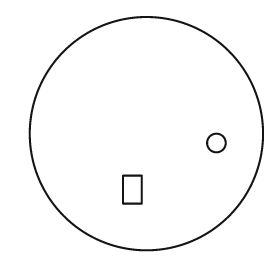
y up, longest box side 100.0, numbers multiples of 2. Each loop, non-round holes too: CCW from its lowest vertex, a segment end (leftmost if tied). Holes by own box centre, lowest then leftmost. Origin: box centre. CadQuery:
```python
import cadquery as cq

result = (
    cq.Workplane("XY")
    .moveTo(0.0, 0.0)
    .circle(50.0)
    .moveTo(-10.0, -30.0)
    .lineTo(-2.0, -30.0)
    .lineTo(-2.0, -18.0)
    .lineTo(-10.0, -18.0)
    .close()
    .moveTo(30.0, -4.0)
    .circle(4.0)
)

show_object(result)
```